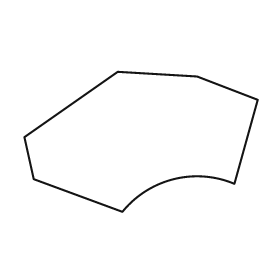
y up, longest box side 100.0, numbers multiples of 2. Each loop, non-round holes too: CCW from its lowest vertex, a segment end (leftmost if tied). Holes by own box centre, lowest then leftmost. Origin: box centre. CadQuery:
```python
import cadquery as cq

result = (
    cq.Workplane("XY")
    .moveTo(-8.0, -30.0)
    .threePointArc((14.0, -16.0), (40.0, -18.0))
    .lineTo(50.0, 18.0)
    .lineTo(24.0, 28.0)
    .lineTo(-10.0, 30.0)
    .lineTo(-50.0, 2.0)
    .lineTo(-46.0, -16.0)
    .close()
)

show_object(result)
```